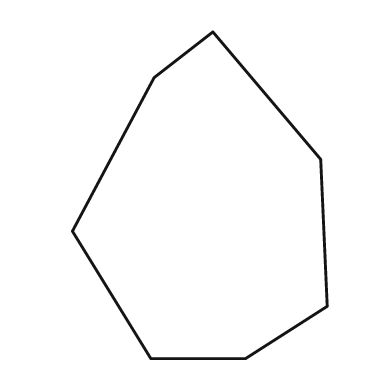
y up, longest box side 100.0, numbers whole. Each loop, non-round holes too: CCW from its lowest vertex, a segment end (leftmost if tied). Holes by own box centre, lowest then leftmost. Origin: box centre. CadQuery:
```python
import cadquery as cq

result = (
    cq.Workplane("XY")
    .moveTo(-15.0, -50.0)
    .lineTo(14.0, -50.0)
    .lineTo(39.0, -34.0)
    .lineTo(37.0, 11.0)
    .lineTo(4.0, 50.0)
    .lineTo(-14.0, 36.0)
    .lineTo(-39.0, -11.0)
    .close()
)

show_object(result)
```